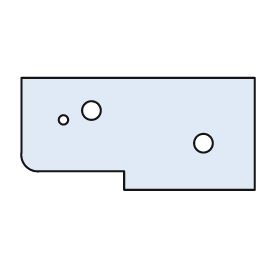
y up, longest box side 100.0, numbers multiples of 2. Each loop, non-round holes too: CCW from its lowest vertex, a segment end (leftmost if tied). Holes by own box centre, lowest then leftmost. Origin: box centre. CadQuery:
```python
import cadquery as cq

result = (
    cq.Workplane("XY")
    .moveTo(-6.0, -24.0)
    .lineTo(50.0, -24.0)
    .lineTo(50.0, 24.0)
    .lineTo(-50.0, 24.0)
    .lineTo(-50.0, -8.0)
    .threePointArc((-48.0, -14.0), (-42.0, -16.0))
    .lineTo(-6.0, -16.0)
    .close()
    .moveTo(28.0, -4.0)
    .circle(4.0)
    .moveTo(-32.0, 6.0)
    .circle(2.0)
    .moveTo(-20.0, 10.0)
    .circle(4.0)
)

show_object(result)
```